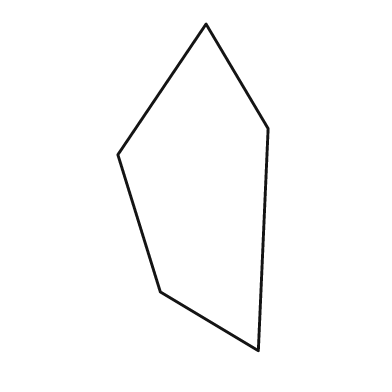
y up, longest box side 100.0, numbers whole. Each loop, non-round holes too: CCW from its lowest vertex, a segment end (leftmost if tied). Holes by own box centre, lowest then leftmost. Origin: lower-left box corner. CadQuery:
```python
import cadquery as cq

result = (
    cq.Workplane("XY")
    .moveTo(43.0, 0.0)
    .lineTo(46.0, 68.0)
    .lineTo(27.0, 100.0)
    .lineTo(0.0, 60.0)
    .lineTo(13.0, 18.0)
    .close()
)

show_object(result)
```